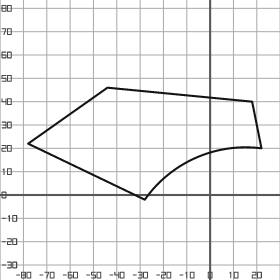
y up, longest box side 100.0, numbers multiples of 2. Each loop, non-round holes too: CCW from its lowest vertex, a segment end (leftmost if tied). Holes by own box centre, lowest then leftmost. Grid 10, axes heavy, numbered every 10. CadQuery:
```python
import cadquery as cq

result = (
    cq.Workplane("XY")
    .moveTo(-28.0, -2.0)
    .threePointArc((-6.0, 16.0), (22.0, 20.0))
    .lineTo(18.0, 40.0)
    .lineTo(-44.0, 46.0)
    .lineTo(-78.0, 22.0)
    .close()
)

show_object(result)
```